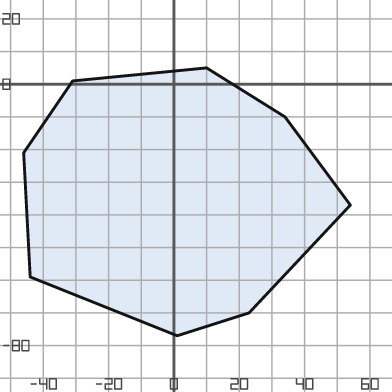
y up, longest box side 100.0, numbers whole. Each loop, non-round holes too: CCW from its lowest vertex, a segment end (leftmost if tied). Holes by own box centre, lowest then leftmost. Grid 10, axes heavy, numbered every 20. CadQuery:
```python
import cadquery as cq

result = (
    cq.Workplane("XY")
    .moveTo(1.0, -77.0)
    .lineTo(23.0, -70.0)
    .lineTo(54.0, -37.0)
    .lineTo(34.0, -10.0)
    .lineTo(10.0, 5.0)
    .lineTo(-31.0, 1.0)
    .lineTo(-46.0, -21.0)
    .lineTo(-44.0, -59.0)
    .close()
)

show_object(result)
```